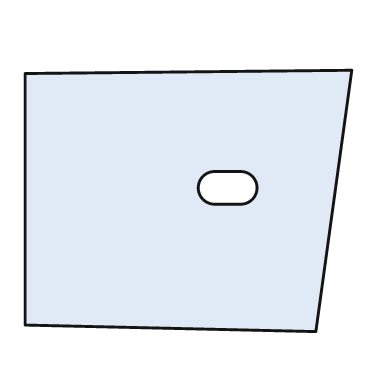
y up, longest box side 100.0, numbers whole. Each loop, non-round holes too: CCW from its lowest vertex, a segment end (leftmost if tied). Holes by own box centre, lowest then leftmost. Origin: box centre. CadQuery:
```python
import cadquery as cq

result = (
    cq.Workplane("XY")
    .moveTo(39.0, -40.0)
    .lineTo(50.0, 40.0)
    .lineTo(-50.0, 39.0)
    .lineTo(-50.0, -38.0)
    .close()
    .moveTo(8.0, -1.0)
    .lineTo(16.0, -1.0)
    .threePointArc((21.0, 4.0), (16.0, 9.0))
    .lineTo(8.0, 9.0)
    .threePointArc((3.0, 4.0), (8.0, -1.0))
    .close()
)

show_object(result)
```